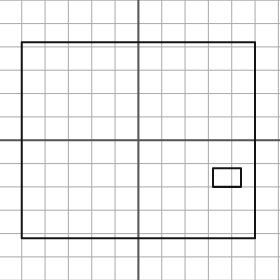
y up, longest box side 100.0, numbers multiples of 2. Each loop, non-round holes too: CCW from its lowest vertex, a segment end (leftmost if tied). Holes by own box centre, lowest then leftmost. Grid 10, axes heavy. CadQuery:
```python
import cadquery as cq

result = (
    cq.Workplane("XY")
    .moveTo(-50.0, -42.0)
    .lineTo(50.0, -42.0)
    .lineTo(50.0, 42.0)
    .lineTo(-50.0, 42.0)
    .close()
    .moveTo(32.0, -20.0)
    .lineTo(44.0, -20.0)
    .lineTo(44.0, -12.0)
    .lineTo(32.0, -12.0)
    .close()
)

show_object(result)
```